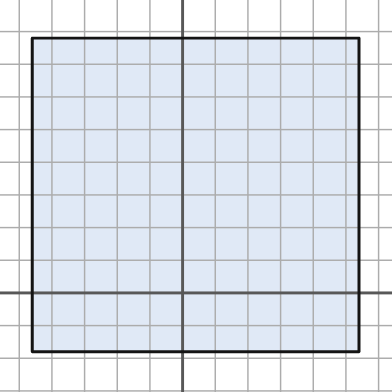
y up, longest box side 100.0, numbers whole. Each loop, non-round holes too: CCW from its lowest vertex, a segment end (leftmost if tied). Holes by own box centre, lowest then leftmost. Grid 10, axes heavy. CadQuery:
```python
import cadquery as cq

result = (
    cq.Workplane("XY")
    .moveTo(-46.0, -18.0)
    .lineTo(54.0, -18.0)
    .lineTo(54.0, 78.0)
    .lineTo(-46.0, 78.0)
    .close()
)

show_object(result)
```